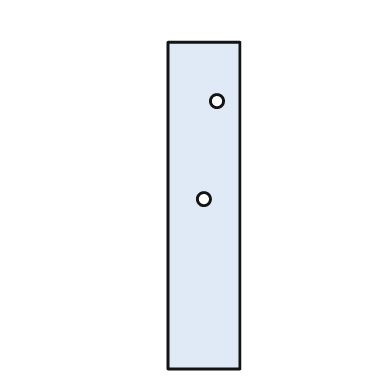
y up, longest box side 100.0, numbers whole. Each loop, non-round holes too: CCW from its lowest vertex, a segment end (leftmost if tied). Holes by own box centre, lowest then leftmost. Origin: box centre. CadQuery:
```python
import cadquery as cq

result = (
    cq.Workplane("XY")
    .moveTo(-11.0, -50.0)
    .lineTo(11.0, -50.0)
    .lineTo(11.0, 50.0)
    .lineTo(-11.0, 50.0)
    .close()
    .moveTo(0.0, 2.0)
    .circle(2.0)
    .moveTo(4.0, 32.0)
    .circle(2.0)
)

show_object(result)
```